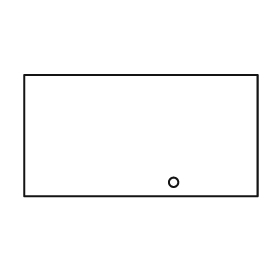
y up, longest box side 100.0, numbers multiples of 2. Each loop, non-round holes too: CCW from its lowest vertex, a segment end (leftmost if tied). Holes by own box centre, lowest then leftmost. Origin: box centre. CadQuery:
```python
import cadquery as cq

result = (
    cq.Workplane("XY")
    .moveTo(-50.0, -26.0)
    .lineTo(50.0, -26.0)
    .lineTo(50.0, 26.0)
    .lineTo(-50.0, 26.0)
    .close()
    .moveTo(14.0, -20.0)
    .circle(2.0)
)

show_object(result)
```